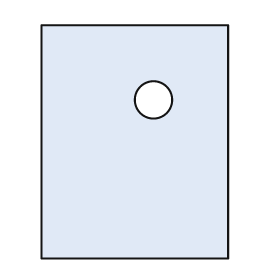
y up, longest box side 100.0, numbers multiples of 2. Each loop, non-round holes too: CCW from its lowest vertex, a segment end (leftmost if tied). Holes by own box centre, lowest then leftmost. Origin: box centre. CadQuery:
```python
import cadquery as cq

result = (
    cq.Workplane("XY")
    .moveTo(-40.0, -50.0)
    .lineTo(40.0, -50.0)
    .lineTo(40.0, 50.0)
    .lineTo(-40.0, 50.0)
    .close()
    .moveTo(8.0, 18.0)
    .circle(8.0)
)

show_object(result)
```